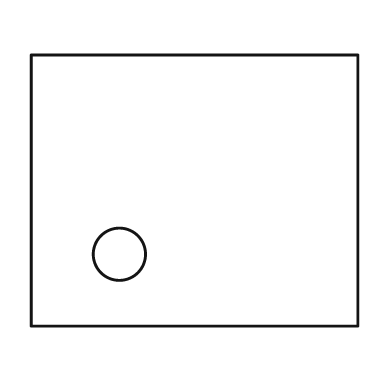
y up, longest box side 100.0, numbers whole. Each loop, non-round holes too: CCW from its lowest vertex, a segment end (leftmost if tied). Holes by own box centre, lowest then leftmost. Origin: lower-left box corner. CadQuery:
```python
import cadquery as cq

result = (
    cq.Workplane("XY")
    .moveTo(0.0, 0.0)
    .lineTo(100.0, 0.0)
    .lineTo(100.0, 83.0)
    .lineTo(0.0, 83.0)
    .close()
    .moveTo(27.0, 22.0)
    .circle(8.0)
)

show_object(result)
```